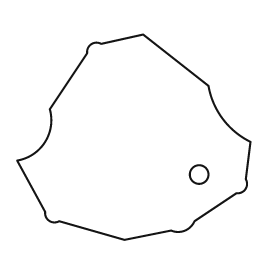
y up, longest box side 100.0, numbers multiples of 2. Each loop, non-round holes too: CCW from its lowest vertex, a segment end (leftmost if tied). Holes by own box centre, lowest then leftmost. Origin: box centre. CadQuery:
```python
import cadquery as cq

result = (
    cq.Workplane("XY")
    .moveTo(-4.0, -44.0)
    .lineTo(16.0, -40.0)
    .threePointArc((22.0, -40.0), (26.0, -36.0))
    .lineTo(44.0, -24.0)
    .threePointArc((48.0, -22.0), (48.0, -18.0))
    .lineTo(50.0, -2.0)
    .threePointArc((38.0, 8.0), (32.0, 22.0))
    .lineTo(4.0, 44.0)
    .lineTo(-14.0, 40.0)
    .threePointArc((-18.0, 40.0), (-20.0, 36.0))
    .lineTo(-36.0, 12.0)
    .threePointArc((-38.0, -2.0), (-50.0, -10.0))
    .lineTo(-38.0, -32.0)
    .threePointArc((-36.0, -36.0), (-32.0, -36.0))
    .close()
    .moveTo(28.0, -16.0)
    .circle(4.0)
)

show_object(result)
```